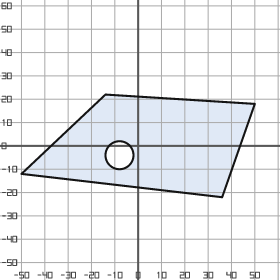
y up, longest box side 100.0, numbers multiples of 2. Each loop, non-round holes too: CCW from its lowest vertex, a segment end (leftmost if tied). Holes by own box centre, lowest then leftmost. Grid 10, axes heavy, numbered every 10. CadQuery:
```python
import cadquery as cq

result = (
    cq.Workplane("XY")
    .moveTo(36.0, -22.0)
    .lineTo(50.0, 18.0)
    .lineTo(-14.0, 22.0)
    .lineTo(-50.0, -12.0)
    .close()
    .moveTo(-8.0, -4.0)
    .circle(6.0)
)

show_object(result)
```